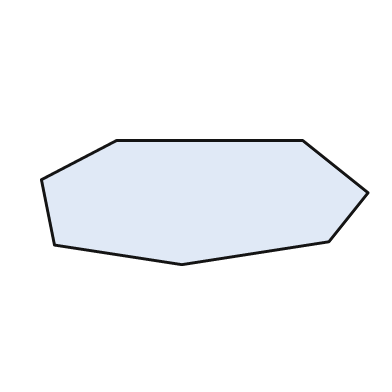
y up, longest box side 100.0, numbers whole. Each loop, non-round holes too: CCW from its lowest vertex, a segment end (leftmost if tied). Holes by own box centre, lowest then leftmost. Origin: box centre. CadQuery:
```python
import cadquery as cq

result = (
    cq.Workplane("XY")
    .moveTo(-7.0, -19.0)
    .lineTo(38.0, -12.0)
    .lineTo(50.0, 3.0)
    .lineTo(30.0, 19.0)
    .lineTo(-27.0, 19.0)
    .lineTo(-50.0, 7.0)
    .lineTo(-46.0, -13.0)
    .close()
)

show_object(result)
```